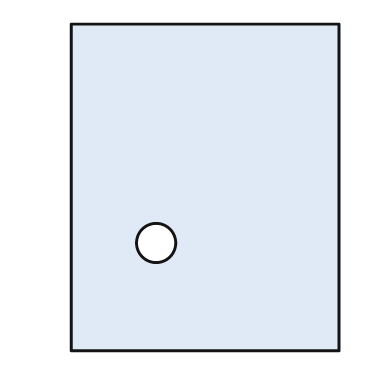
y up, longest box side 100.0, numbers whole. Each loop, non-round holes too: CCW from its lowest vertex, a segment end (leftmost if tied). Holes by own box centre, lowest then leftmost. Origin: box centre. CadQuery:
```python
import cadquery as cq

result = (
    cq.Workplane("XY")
    .moveTo(-41.0, -50.0)
    .lineTo(41.0, -50.0)
    .lineTo(41.0, 50.0)
    .lineTo(-41.0, 50.0)
    .close()
    .moveTo(-15.0, -17.0)
    .circle(6.0)
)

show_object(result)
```